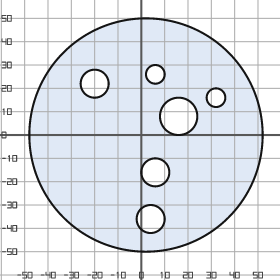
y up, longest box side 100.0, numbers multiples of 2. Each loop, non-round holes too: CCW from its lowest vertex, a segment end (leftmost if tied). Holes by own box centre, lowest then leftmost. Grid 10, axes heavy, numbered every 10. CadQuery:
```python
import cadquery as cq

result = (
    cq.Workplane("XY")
    .moveTo(2.0, 0.0)
    .circle(50.0)
    .moveTo(4.0, -36.0)
    .circle(6.0)
    .moveTo(6.0, -16.0)
    .circle(6.0)
    .moveTo(16.0, 8.0)
    .circle(8.0)
    .moveTo(32.0, 16.0)
    .circle(4.0)
    .moveTo(-20.0, 22.0)
    .circle(6.0)
    .moveTo(6.0, 26.0)
    .circle(4.0)
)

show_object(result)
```